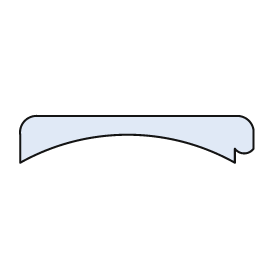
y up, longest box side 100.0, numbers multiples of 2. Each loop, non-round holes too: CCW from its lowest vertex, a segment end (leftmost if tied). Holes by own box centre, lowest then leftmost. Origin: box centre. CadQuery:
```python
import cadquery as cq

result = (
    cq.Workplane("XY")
    .moveTo(-50.0, -10.0)
    .threePointArc((-4.0, 2.0), (42.0, -10.0))
    .lineTo(42.0, -4.0)
    .threePointArc((46.0, -6.0), (50.0, -4.0))
    .lineTo(50.0, 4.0)
    .threePointArc((48.0, 8.0), (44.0, 10.0))
    .lineTo(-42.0, 10.0)
    .threePointArc((-48.0, 8.0), (-50.0, 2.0))
    .close()
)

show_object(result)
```